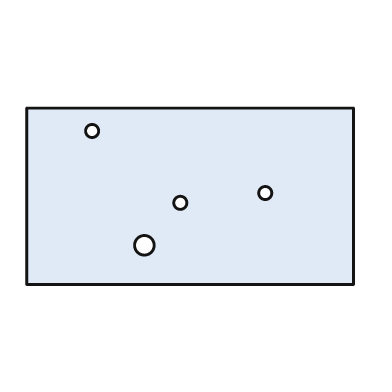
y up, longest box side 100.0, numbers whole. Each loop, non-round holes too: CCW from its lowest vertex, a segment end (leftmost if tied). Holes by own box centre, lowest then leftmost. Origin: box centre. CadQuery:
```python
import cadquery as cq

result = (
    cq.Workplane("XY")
    .moveTo(-50.0, -27.0)
    .lineTo(50.0, -27.0)
    .lineTo(50.0, 27.0)
    .lineTo(-50.0, 27.0)
    .close()
    .moveTo(-14.0, -15.0)
    .circle(3.0)
    .moveTo(-3.0, -2.0)
    .circle(2.0)
    .moveTo(23.0, 1.0)
    .circle(2.0)
    .moveTo(-30.0, 20.0)
    .circle(2.0)
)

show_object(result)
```